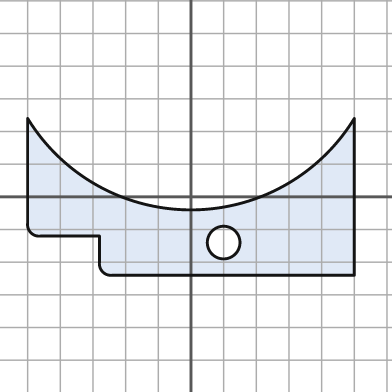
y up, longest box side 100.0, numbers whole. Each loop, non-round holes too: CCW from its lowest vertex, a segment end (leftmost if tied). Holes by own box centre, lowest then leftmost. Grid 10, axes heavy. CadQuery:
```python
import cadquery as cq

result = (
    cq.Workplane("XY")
    .moveTo(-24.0, -24.0)
    .lineTo(50.0, -24.0)
    .lineTo(50.0, 24.0)
    .threePointArc((0.0, -4.0), (-50.0, 24.0))
    .lineTo(-50.0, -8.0)
    .threePointArc((-49.0, -11.0), (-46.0, -12.0))
    .lineTo(-28.0, -12.0)
    .lineTo(-28.0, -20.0)
    .threePointArc((-27.0, -23.0), (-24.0, -24.0))
    .close()
    .moveTo(10.0, -14.0)
    .circle(5.0)
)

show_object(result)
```